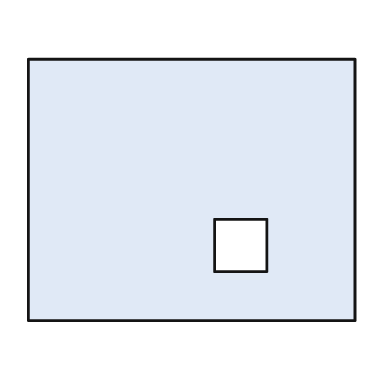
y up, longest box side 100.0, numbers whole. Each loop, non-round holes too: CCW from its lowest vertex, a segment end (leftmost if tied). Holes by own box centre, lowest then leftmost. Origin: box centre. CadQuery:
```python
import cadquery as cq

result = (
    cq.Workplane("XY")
    .moveTo(-50.0, -40.0)
    .lineTo(50.0, -40.0)
    .lineTo(50.0, 40.0)
    .lineTo(-50.0, 40.0)
    .close()
    .moveTo(7.0, -25.0)
    .lineTo(23.0, -25.0)
    .lineTo(23.0, -9.0)
    .lineTo(7.0, -9.0)
    .close()
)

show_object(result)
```